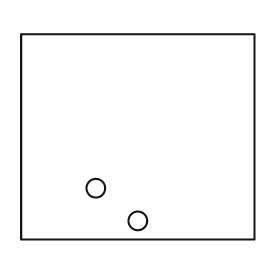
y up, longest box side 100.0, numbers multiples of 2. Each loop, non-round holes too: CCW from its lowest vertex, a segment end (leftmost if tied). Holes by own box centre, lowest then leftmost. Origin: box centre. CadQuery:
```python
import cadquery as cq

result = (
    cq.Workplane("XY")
    .moveTo(-50.0, -44.0)
    .lineTo(50.0, -44.0)
    .lineTo(50.0, 44.0)
    .lineTo(-50.0, 44.0)
    .close()
    .moveTo(0.0, -36.0)
    .circle(4.0)
    .moveTo(-18.0, -22.0)
    .circle(4.0)
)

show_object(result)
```